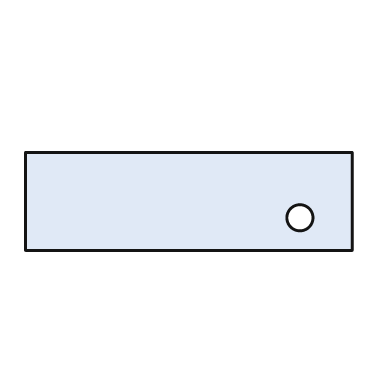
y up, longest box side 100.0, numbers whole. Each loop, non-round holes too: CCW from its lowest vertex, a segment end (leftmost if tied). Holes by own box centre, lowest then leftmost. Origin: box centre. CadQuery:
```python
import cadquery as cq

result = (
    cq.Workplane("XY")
    .moveTo(-50.0, -15.0)
    .lineTo(50.0, -15.0)
    .lineTo(50.0, 15.0)
    .lineTo(-50.0, 15.0)
    .close()
    .moveTo(34.0, -5.0)
    .circle(4.0)
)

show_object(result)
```